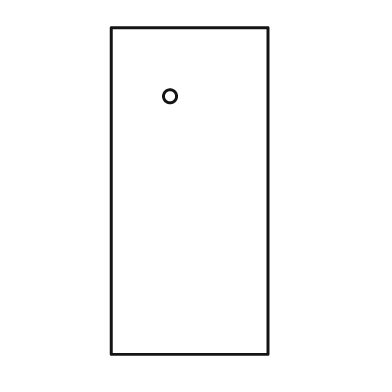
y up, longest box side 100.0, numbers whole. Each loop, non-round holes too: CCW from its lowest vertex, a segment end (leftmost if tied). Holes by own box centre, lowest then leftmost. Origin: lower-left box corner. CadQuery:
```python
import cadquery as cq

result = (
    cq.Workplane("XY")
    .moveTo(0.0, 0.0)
    .lineTo(48.0, 0.0)
    .lineTo(48.0, 100.0)
    .lineTo(0.0, 100.0)
    .close()
    .moveTo(18.0, 79.0)
    .circle(2.0)
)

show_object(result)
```